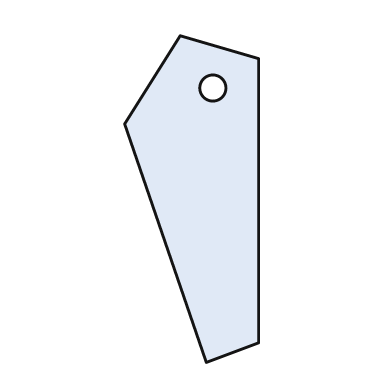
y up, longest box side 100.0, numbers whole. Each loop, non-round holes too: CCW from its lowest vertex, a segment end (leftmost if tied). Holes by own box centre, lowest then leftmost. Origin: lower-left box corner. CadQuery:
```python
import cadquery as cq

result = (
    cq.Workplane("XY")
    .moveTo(25.0, 0.0)
    .lineTo(41.0, 6.0)
    .lineTo(41.0, 93.0)
    .lineTo(17.0, 100.0)
    .lineTo(0.0, 73.0)
    .close()
    .moveTo(27.0, 84.0)
    .circle(4.0)
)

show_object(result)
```